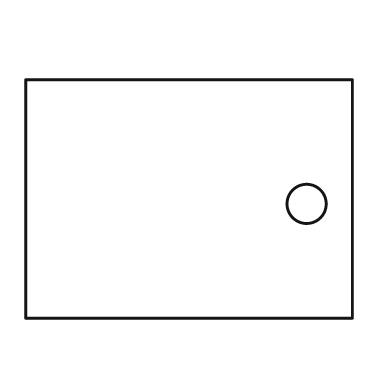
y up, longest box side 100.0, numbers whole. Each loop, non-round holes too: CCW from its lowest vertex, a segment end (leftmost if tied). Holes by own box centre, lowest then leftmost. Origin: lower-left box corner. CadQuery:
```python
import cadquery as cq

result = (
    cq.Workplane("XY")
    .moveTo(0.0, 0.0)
    .lineTo(100.0, 0.0)
    .lineTo(100.0, 73.0)
    .lineTo(0.0, 73.0)
    .close()
    .moveTo(86.0, 35.0)
    .circle(6.0)
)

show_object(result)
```